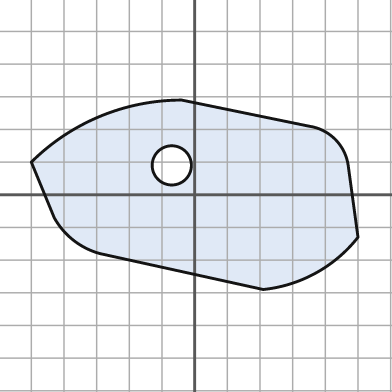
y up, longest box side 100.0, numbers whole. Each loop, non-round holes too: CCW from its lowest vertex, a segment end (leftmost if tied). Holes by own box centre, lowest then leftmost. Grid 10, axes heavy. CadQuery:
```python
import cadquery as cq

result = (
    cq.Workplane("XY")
    .moveTo(21.0, -29.0)
    .threePointArc((37.0, -24.0), (50.0, -13.0))
    .lineTo(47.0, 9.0)
    .threePointArc((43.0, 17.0), (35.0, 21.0))
    .lineTo(-4.0, 29.0)
    .threePointArc((-29.0, 24.0), (-50.0, 10.0))
    .lineTo(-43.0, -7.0)
    .threePointArc((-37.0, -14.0), (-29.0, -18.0))
    .close()
    .moveTo(-7.0, 9.0)
    .circle(6.0)
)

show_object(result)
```